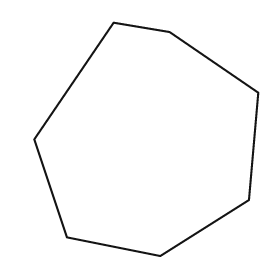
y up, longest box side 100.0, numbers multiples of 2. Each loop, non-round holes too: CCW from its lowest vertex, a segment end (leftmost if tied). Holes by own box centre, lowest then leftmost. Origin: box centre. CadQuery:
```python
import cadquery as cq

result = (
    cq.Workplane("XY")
    .moveTo(6.0, -50.0)
    .lineTo(44.0, -26.0)
    .lineTo(48.0, 20.0)
    .lineTo(10.0, 46.0)
    .lineTo(-14.0, 50.0)
    .lineTo(-48.0, 0.0)
    .lineTo(-34.0, -42.0)
    .close()
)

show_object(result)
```